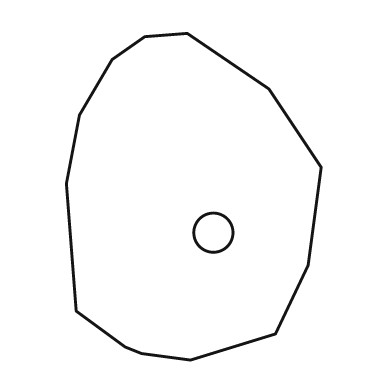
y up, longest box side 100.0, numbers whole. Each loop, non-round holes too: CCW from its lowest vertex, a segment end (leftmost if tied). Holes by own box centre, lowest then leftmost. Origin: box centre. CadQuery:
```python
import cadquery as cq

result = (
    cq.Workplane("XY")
    .moveTo(-1.0, -50.0)
    .lineTo(25.0, -42.0)
    .lineTo(35.0, -21.0)
    .lineTo(39.0, 9.0)
    .lineTo(23.0, 33.0)
    .lineTo(-2.0, 50.0)
    .lineTo(-15.0, 49.0)
    .lineTo(-25.0, 42.0)
    .lineTo(-35.0, 25.0)
    .lineTo(-39.0, 4.0)
    .lineTo(-36.0, -35.0)
    .lineTo(-21.0, -46.0)
    .lineTo(-16.0, -48.0)
    .close()
    .moveTo(6.0, -11.0)
    .circle(6.0)
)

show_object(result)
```